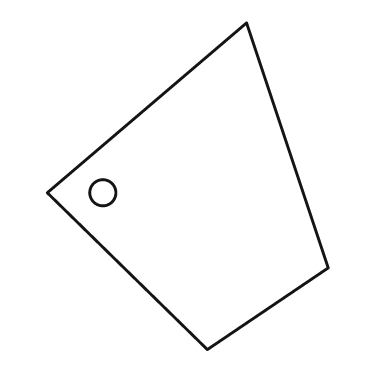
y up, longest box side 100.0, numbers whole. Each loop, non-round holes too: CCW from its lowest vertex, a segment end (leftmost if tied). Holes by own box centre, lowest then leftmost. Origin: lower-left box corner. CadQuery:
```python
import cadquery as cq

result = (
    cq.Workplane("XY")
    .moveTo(49.0, 0.0)
    .lineTo(86.0, 25.0)
    .lineTo(61.0, 100.0)
    .lineTo(0.0, 48.0)
    .close()
    .moveTo(17.0, 48.0)
    .circle(4.0)
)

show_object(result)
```